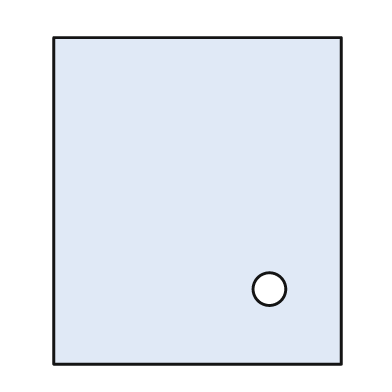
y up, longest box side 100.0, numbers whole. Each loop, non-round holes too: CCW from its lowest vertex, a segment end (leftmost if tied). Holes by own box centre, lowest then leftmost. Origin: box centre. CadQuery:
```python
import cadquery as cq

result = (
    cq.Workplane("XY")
    .moveTo(-44.0, -50.0)
    .lineTo(44.0, -50.0)
    .lineTo(44.0, 50.0)
    .lineTo(-44.0, 50.0)
    .close()
    .moveTo(22.0, -27.0)
    .circle(5.0)
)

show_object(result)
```